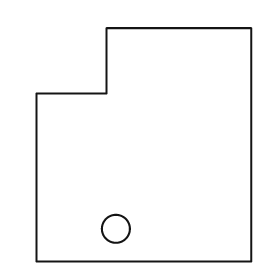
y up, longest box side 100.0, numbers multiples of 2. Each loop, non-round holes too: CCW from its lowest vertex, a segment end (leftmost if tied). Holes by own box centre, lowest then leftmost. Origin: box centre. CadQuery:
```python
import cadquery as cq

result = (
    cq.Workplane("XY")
    .moveTo(-46.0, -50.0)
    .lineTo(46.0, -50.0)
    .lineTo(46.0, 50.0)
    .lineTo(-16.0, 50.0)
    .lineTo(-16.0, 22.0)
    .lineTo(-46.0, 22.0)
    .close()
    .moveTo(-12.0, -36.0)
    .circle(6.0)
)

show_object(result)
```